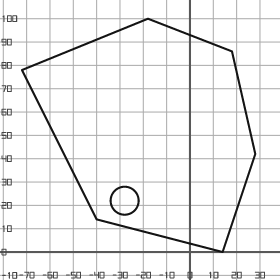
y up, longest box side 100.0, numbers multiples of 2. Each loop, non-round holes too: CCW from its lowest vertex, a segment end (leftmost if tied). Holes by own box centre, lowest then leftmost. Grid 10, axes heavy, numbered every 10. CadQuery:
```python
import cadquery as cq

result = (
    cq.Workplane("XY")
    .moveTo(14.0, 0.0)
    .lineTo(28.0, 42.0)
    .lineTo(18.0, 86.0)
    .lineTo(-18.0, 100.0)
    .lineTo(-72.0, 78.0)
    .lineTo(-40.0, 14.0)
    .close()
    .moveTo(-28.0, 22.0)
    .circle(6.0)
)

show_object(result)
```